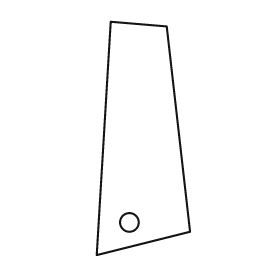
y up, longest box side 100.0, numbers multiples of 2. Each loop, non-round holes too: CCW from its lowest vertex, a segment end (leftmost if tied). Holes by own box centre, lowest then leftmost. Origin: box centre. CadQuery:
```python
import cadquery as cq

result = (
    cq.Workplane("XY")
    .moveTo(-20.0, -50.0)
    .lineTo(20.0, -40.0)
    .lineTo(10.0, 48.0)
    .lineTo(-14.0, 50.0)
    .close()
    .moveTo(-6.0, -36.0)
    .circle(4.0)
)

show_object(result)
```